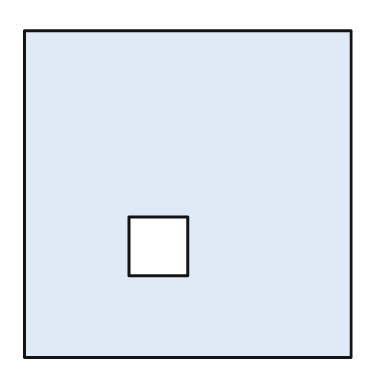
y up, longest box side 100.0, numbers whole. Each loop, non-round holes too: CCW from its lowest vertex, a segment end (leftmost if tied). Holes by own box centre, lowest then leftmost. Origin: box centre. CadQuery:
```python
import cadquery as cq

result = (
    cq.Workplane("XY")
    .moveTo(-50.0, -50.0)
    .lineTo(50.0, -50.0)
    .lineTo(50.0, 50.0)
    .lineTo(-50.0, 50.0)
    .close()
    .moveTo(-18.0, -25.0)
    .lineTo(0.0, -25.0)
    .lineTo(0.0, -7.0)
    .lineTo(-18.0, -7.0)
    .close()
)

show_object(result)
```